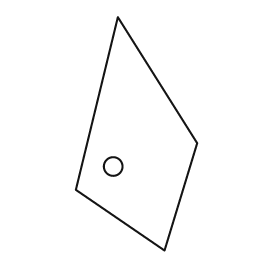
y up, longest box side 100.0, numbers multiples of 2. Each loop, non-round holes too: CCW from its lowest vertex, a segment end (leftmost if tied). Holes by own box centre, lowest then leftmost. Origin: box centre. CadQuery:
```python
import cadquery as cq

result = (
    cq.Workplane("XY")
    .moveTo(12.0, -50.0)
    .lineTo(26.0, -4.0)
    .lineTo(-8.0, 50.0)
    .lineTo(-26.0, -24.0)
    .close()
    .moveTo(-10.0, -14.0)
    .circle(4.0)
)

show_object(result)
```